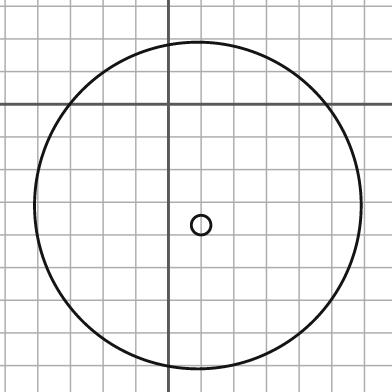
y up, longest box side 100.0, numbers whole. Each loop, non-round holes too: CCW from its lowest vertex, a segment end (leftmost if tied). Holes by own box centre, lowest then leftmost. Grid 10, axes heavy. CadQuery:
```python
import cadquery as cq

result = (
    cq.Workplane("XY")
    .moveTo(9.0, -31.0)
    .circle(50.0)
    .moveTo(10.0, -37.0)
    .circle(3.0)
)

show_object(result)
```